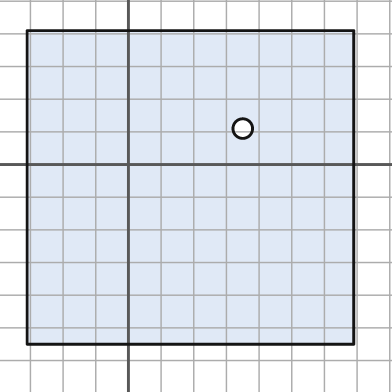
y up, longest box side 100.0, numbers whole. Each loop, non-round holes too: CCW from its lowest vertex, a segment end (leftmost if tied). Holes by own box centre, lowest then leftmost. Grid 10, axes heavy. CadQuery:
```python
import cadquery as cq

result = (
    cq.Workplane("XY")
    .moveTo(-31.0, -55.0)
    .lineTo(69.0, -55.0)
    .lineTo(69.0, 41.0)
    .lineTo(-31.0, 41.0)
    .close()
    .moveTo(35.0, 11.0)
    .circle(3.0)
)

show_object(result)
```